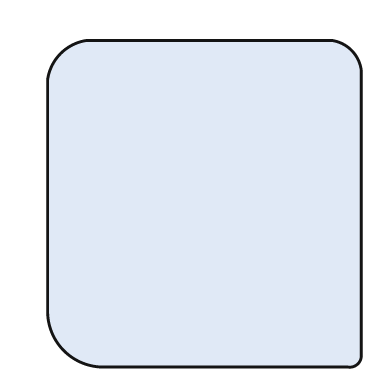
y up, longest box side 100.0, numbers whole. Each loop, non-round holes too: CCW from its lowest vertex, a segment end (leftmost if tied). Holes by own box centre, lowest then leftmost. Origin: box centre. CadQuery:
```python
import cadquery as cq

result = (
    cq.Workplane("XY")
    .moveTo(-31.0, -50.0)
    .lineTo(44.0, -50.0)
    .threePointArc((47.0, -49.0), (48.0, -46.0))
    .lineTo(48.0, 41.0)
    .threePointArc((45.0, 47.0), (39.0, 50.0))
    .lineTo(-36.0, 50.0)
    .threePointArc((-44.0, 46.0), (-48.0, 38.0))
    .lineTo(-48.0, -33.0)
    .threePointArc((-43.0, -45.0), (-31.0, -50.0))
    .close()
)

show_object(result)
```